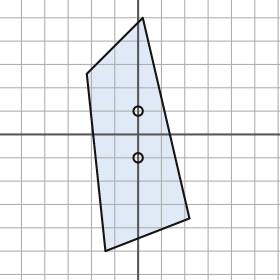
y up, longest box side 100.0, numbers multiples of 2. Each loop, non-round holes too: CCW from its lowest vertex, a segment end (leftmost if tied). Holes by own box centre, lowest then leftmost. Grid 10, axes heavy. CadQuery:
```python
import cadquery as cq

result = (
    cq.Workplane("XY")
    .moveTo(-14.0, -50.0)
    .lineTo(22.0, -36.0)
    .lineTo(2.0, 50.0)
    .lineTo(-22.0, 26.0)
    .close()
    .moveTo(0.0, -10.0)
    .circle(2.0)
    .moveTo(0.0, 10.0)
    .circle(2.0)
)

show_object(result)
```